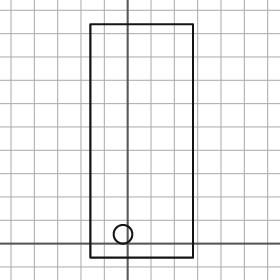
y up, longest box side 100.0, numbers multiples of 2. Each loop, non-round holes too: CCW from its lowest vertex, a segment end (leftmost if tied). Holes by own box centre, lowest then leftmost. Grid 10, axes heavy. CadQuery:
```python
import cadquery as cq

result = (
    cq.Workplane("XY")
    .moveTo(-16.0, -6.0)
    .lineTo(28.0, -6.0)
    .lineTo(28.0, 94.0)
    .lineTo(-16.0, 94.0)
    .close()
    .moveTo(-2.0, 4.0)
    .circle(4.0)
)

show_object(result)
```